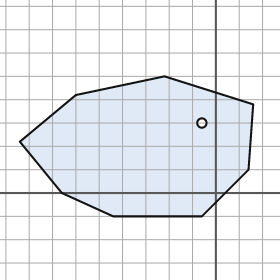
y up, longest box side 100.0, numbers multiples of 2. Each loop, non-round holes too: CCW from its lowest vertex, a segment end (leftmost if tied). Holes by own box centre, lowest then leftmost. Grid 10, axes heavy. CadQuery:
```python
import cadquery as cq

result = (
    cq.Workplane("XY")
    .moveTo(-44.0, -10.0)
    .lineTo(-6.0, -10.0)
    .lineTo(14.0, 10.0)
    .lineTo(16.0, 38.0)
    .lineTo(-22.0, 50.0)
    .lineTo(-60.0, 42.0)
    .lineTo(-84.0, 22.0)
    .lineTo(-66.0, 0.0)
    .close()
    .moveTo(-6.0, 30.0)
    .circle(2.0)
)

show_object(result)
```